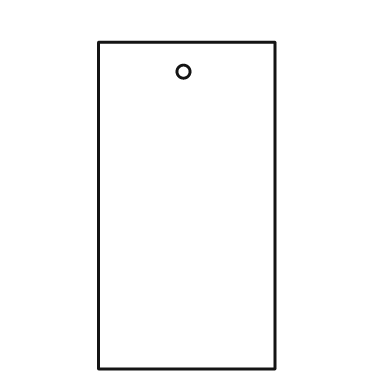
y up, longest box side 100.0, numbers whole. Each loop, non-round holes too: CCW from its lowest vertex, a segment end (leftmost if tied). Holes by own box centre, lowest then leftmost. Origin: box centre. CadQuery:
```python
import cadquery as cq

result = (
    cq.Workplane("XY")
    .moveTo(-27.0, -50.0)
    .lineTo(27.0, -50.0)
    .lineTo(27.0, 50.0)
    .lineTo(-27.0, 50.0)
    .close()
    .moveTo(-1.0, 41.0)
    .circle(2.0)
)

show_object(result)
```